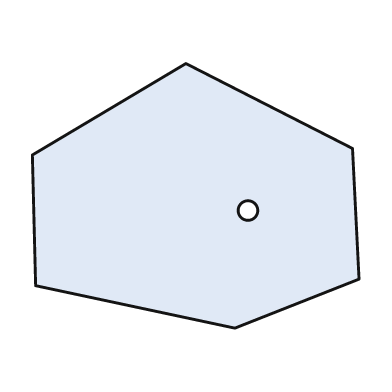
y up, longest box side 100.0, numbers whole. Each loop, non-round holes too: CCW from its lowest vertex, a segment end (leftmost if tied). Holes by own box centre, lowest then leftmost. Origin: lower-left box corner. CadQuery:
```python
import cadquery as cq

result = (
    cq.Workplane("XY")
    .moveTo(62.0, 0.0)
    .lineTo(100.0, 15.0)
    .lineTo(98.0, 55.0)
    .lineTo(47.0, 81.0)
    .lineTo(0.0, 53.0)
    .lineTo(1.0, 13.0)
    .close()
    .moveTo(66.0, 36.0)
    .circle(3.0)
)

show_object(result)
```